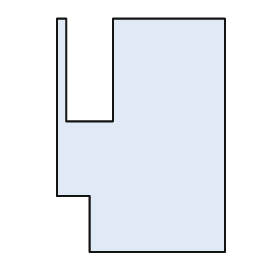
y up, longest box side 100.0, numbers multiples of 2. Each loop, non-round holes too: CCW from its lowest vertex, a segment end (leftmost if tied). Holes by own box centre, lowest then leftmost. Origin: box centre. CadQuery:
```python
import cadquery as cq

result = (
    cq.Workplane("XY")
    .moveTo(-22.0, -50.0)
    .lineTo(36.0, -50.0)
    .lineTo(36.0, 50.0)
    .lineTo(-12.0, 50.0)
    .lineTo(-12.0, 6.0)
    .lineTo(-32.0, 6.0)
    .lineTo(-32.0, 50.0)
    .lineTo(-36.0, 50.0)
    .lineTo(-36.0, -26.0)
    .lineTo(-22.0, -26.0)
    .close()
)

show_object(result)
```